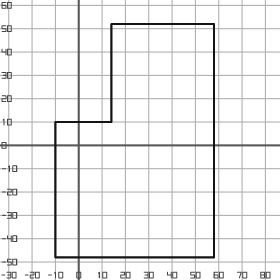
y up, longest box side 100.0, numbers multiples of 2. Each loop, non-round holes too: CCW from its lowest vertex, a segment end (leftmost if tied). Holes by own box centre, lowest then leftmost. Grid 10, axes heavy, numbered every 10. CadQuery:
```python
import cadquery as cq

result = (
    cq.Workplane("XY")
    .moveTo(-10.0, -48.0)
    .lineTo(58.0, -48.0)
    .lineTo(58.0, 52.0)
    .lineTo(14.0, 52.0)
    .lineTo(14.0, 10.0)
    .lineTo(-10.0, 10.0)
    .close()
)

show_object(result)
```